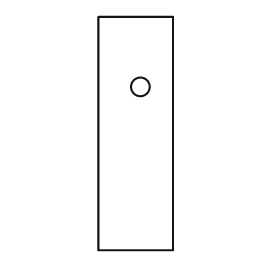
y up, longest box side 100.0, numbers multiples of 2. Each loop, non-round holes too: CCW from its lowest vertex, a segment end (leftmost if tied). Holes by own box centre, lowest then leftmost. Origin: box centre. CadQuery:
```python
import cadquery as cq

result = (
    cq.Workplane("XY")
    .moveTo(-16.0, -50.0)
    .lineTo(16.0, -50.0)
    .lineTo(16.0, 50.0)
    .lineTo(-16.0, 50.0)
    .close()
    .moveTo(2.0, 20.0)
    .circle(4.0)
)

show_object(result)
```